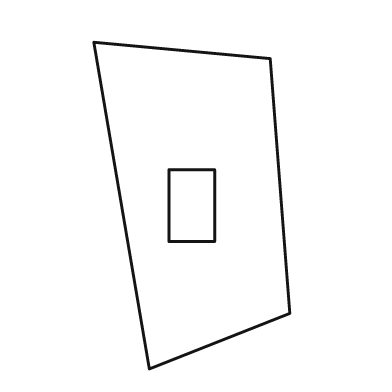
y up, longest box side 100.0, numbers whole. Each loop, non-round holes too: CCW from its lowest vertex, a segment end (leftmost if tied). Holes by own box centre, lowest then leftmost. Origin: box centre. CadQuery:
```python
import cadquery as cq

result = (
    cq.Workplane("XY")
    .moveTo(-13.0, -50.0)
    .lineTo(30.0, -33.0)
    .lineTo(24.0, 45.0)
    .lineTo(-30.0, 50.0)
    .close()
    .moveTo(-7.0, -11.0)
    .lineTo(7.0, -11.0)
    .lineTo(7.0, 11.0)
    .lineTo(-7.0, 11.0)
    .close()
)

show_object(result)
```